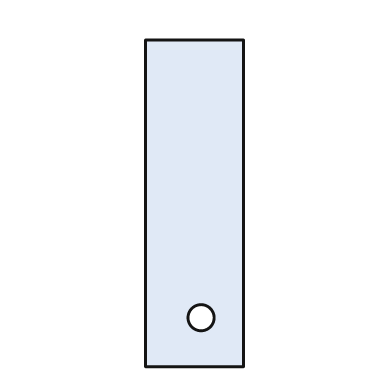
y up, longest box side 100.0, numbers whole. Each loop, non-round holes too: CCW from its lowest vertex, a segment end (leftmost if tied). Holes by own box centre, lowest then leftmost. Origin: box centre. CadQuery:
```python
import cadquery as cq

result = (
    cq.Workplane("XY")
    .moveTo(-15.0, -50.0)
    .lineTo(15.0, -50.0)
    .lineTo(15.0, 50.0)
    .lineTo(-15.0, 50.0)
    .close()
    .moveTo(2.0, -35.0)
    .circle(4.0)
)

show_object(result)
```